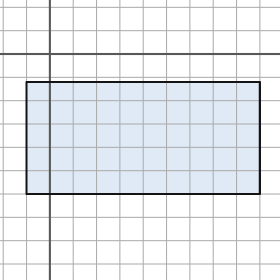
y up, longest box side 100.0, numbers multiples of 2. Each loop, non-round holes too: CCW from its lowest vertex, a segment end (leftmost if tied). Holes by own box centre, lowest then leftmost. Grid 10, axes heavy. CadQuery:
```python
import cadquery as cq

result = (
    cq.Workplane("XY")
    .moveTo(-10.0, -60.0)
    .lineTo(90.0, -60.0)
    .lineTo(90.0, -12.0)
    .lineTo(-10.0, -12.0)
    .close()
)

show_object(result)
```